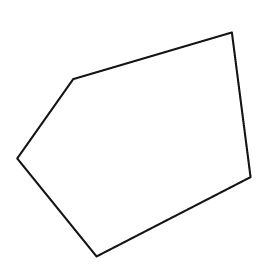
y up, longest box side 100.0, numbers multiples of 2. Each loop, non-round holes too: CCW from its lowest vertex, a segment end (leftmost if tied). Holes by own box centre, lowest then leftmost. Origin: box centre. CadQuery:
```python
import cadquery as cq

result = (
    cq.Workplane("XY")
    .moveTo(-16.0, -48.0)
    .lineTo(50.0, -14.0)
    .lineTo(42.0, 48.0)
    .lineTo(-26.0, 28.0)
    .lineTo(-50.0, -6.0)
    .close()
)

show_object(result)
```